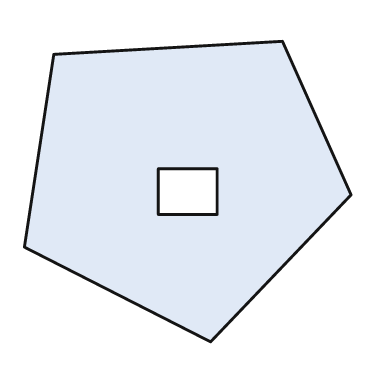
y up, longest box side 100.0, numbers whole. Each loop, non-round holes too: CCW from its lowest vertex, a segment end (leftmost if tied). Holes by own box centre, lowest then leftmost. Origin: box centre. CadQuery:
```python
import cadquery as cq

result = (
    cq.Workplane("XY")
    .moveTo(7.0, -46.0)
    .lineTo(50.0, -1.0)
    .lineTo(29.0, 46.0)
    .lineTo(-41.0, 42.0)
    .lineTo(-50.0, -17.0)
    .close()
    .moveTo(-9.0, -7.0)
    .lineTo(9.0, -7.0)
    .lineTo(9.0, 7.0)
    .lineTo(-9.0, 7.0)
    .close()
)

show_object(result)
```